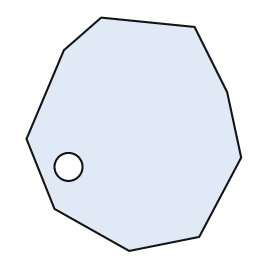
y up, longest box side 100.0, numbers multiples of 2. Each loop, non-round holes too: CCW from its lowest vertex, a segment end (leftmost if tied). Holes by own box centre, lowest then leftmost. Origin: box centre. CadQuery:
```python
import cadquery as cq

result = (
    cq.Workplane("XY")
    .moveTo(-2.0, -50.0)
    .lineTo(28.0, -44.0)
    .lineTo(46.0, -10.0)
    .lineTo(40.0, 18.0)
    .lineTo(26.0, 46.0)
    .lineTo(-14.0, 50.0)
    .lineTo(-30.0, 36.0)
    .lineTo(-46.0, -2.0)
    .lineTo(-34.0, -32.0)
    .close()
    .moveTo(-28.0, -14.0)
    .circle(6.0)
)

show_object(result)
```